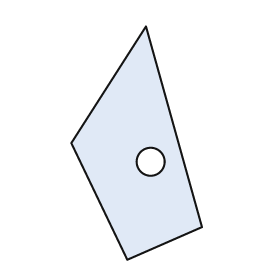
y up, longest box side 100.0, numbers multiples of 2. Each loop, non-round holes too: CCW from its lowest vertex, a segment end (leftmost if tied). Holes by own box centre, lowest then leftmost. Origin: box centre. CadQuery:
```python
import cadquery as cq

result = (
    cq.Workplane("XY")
    .moveTo(-4.0, -50.0)
    .lineTo(28.0, -36.0)
    .lineTo(4.0, 50.0)
    .lineTo(-28.0, 0.0)
    .close()
    .moveTo(6.0, -8.0)
    .circle(6.0)
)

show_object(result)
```